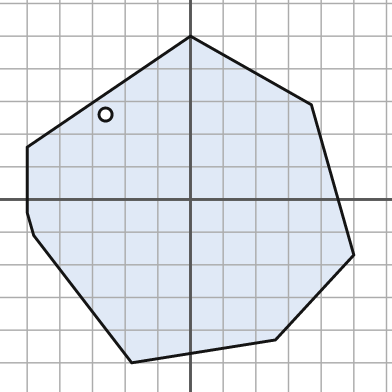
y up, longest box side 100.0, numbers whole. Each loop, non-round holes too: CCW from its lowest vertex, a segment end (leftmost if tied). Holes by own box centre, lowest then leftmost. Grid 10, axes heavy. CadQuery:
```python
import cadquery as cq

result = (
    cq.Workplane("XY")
    .moveTo(-18.0, -50.0)
    .lineTo(26.0, -43.0)
    .lineTo(50.0, -17.0)
    .lineTo(37.0, 29.0)
    .lineTo(0.0, 50.0)
    .lineTo(-50.0, 16.0)
    .lineTo(-50.0, -4.0)
    .lineTo(-48.0, -11.0)
    .close()
    .moveTo(-26.0, 26.0)
    .circle(2.0)
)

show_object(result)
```